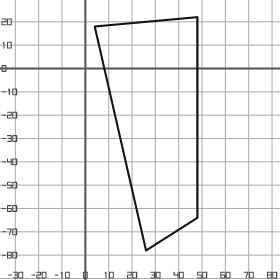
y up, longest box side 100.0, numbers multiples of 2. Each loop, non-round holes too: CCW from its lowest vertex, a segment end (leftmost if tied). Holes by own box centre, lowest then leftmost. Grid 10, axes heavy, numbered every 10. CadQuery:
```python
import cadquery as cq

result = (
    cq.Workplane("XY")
    .moveTo(26.0, -78.0)
    .lineTo(48.0, -64.0)
    .lineTo(48.0, 22.0)
    .lineTo(4.0, 18.0)
    .close()
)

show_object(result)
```